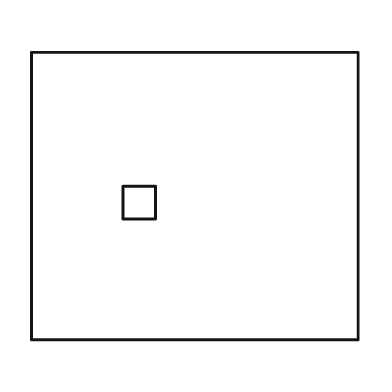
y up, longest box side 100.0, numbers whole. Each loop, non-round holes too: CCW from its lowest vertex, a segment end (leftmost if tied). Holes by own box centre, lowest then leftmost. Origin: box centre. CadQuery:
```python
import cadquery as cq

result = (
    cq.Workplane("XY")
    .moveTo(-50.0, -44.0)
    .lineTo(50.0, -44.0)
    .lineTo(50.0, 44.0)
    .lineTo(-50.0, 44.0)
    .close()
    .moveTo(-22.0, -7.0)
    .lineTo(-12.0, -7.0)
    .lineTo(-12.0, 3.0)
    .lineTo(-22.0, 3.0)
    .close()
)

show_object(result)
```